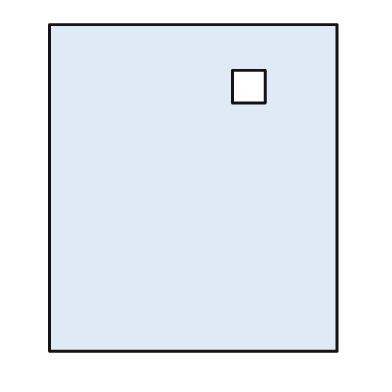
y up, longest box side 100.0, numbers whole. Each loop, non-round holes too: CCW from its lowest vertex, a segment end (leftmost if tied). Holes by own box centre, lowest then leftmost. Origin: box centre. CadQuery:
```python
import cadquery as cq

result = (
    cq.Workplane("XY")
    .moveTo(-44.0, -50.0)
    .lineTo(44.0, -50.0)
    .lineTo(44.0, 50.0)
    .lineTo(-44.0, 50.0)
    .close()
    .moveTo(12.0, 26.0)
    .lineTo(22.0, 26.0)
    .lineTo(22.0, 36.0)
    .lineTo(12.0, 36.0)
    .close()
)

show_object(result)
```